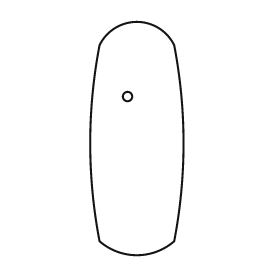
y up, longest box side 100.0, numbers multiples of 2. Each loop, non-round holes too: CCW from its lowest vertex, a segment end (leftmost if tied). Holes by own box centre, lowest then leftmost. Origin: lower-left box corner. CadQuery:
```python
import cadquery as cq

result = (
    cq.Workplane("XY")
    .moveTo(4.0, 6.0)
    .threePointArc((20.0, 0.0), (36.0, 6.0))
    .threePointArc((40.0, 48.0), (36.0, 90.0))
    .threePointArc((20.0, 100.0), (4.0, 90.0))
    .threePointArc((0.0, 48.0), (4.0, 6.0))
    .close()
    .moveTo(16.0, 68.0)
    .circle(2.0)
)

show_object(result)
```